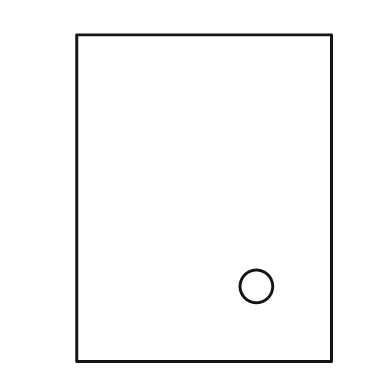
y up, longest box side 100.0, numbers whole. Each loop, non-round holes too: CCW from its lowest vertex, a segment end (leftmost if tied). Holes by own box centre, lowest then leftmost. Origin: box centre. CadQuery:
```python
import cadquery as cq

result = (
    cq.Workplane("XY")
    .moveTo(-39.0, -50.0)
    .lineTo(39.0, -50.0)
    .lineTo(39.0, 50.0)
    .lineTo(-39.0, 50.0)
    .close()
    .moveTo(16.0, -27.0)
    .circle(5.0)
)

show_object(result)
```